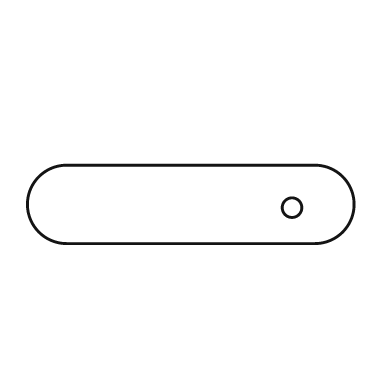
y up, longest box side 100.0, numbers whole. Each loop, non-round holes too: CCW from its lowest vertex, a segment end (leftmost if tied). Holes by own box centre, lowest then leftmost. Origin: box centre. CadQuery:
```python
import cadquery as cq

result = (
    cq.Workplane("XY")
    .moveTo(-38.0, -12.0)
    .lineTo(38.0, -12.0)
    .threePointArc((50.0, 0.0), (38.0, 12.0))
    .lineTo(-38.0, 12.0)
    .threePointArc((-50.0, 0.0), (-38.0, -12.0))
    .close()
    .moveTo(31.0, -1.0)
    .circle(3.0)
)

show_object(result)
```